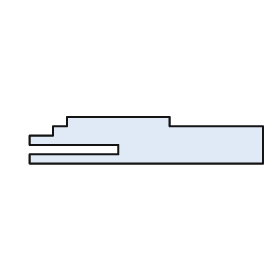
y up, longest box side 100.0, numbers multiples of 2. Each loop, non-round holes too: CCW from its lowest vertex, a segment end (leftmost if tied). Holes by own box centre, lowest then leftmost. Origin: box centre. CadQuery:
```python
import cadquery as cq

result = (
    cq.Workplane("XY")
    .moveTo(-50.0, -10.0)
    .lineTo(50.0, -10.0)
    .lineTo(50.0, 6.0)
    .lineTo(10.0, 6.0)
    .lineTo(10.0, 10.0)
    .lineTo(-34.0, 10.0)
    .lineTo(-34.0, 6.0)
    .lineTo(-40.0, 6.0)
    .lineTo(-40.0, 2.0)
    .lineTo(-50.0, 2.0)
    .lineTo(-50.0, -2.0)
    .lineTo(-12.0, -2.0)
    .lineTo(-12.0, -6.0)
    .lineTo(-50.0, -6.0)
    .close()
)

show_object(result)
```